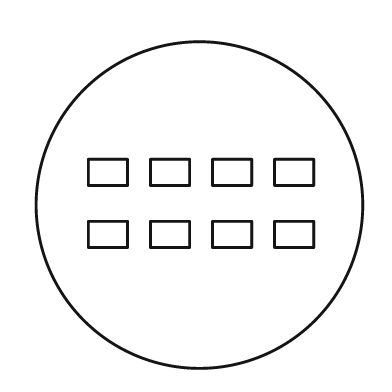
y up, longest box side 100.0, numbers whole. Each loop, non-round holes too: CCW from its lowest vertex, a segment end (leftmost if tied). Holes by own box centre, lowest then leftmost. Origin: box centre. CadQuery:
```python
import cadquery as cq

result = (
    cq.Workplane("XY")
    .moveTo(0.0, 0.0)
    .circle(50.0)
    .moveTo(-34.0, -13.0)
    .lineTo(-22.0, -13.0)
    .lineTo(-22.0, -5.0)
    .lineTo(-34.0, -5.0)
    .close()
    .moveTo(-15.0, -13.0)
    .lineTo(-3.0, -13.0)
    .lineTo(-3.0, -5.0)
    .lineTo(-15.0, -5.0)
    .close()
    .moveTo(4.0, -13.0)
    .lineTo(16.0, -13.0)
    .lineTo(16.0, -5.0)
    .lineTo(4.0, -5.0)
    .close()
    .moveTo(23.0, -13.0)
    .lineTo(35.0, -13.0)
    .lineTo(35.0, -5.0)
    .lineTo(23.0, -5.0)
    .close()
    .moveTo(-34.0, 6.0)
    .lineTo(-22.0, 6.0)
    .lineTo(-22.0, 14.0)
    .lineTo(-34.0, 14.0)
    .close()
    .moveTo(-15.0, 6.0)
    .lineTo(-3.0, 6.0)
    .lineTo(-3.0, 14.0)
    .lineTo(-15.0, 14.0)
    .close()
    .moveTo(4.0, 6.0)
    .lineTo(16.0, 6.0)
    .lineTo(16.0, 14.0)
    .lineTo(4.0, 14.0)
    .close()
    .moveTo(23.0, 6.0)
    .lineTo(35.0, 6.0)
    .lineTo(35.0, 14.0)
    .lineTo(23.0, 14.0)
    .close()
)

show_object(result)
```